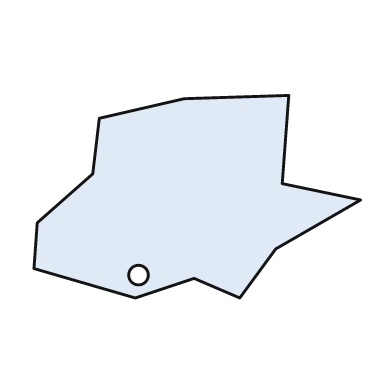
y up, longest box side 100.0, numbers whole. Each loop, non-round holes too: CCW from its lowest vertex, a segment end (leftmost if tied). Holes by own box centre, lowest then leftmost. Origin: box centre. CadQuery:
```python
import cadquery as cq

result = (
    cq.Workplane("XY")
    .moveTo(-19.0, -31.0)
    .lineTo(-1.0, -25.0)
    .lineTo(13.0, -31.0)
    .lineTo(24.0, -16.0)
    .lineTo(50.0, -1.0)
    .lineTo(26.0, 4.0)
    .lineTo(28.0, 31.0)
    .lineTo(-4.0, 30.0)
    .lineTo(-30.0, 24.0)
    .lineTo(-32.0, 7.0)
    .lineTo(-49.0, -8.0)
    .lineTo(-50.0, -22.0)
    .close()
    .moveTo(-18.0, -24.0)
    .circle(3.0)
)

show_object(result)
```